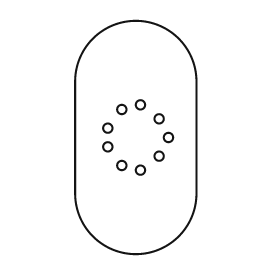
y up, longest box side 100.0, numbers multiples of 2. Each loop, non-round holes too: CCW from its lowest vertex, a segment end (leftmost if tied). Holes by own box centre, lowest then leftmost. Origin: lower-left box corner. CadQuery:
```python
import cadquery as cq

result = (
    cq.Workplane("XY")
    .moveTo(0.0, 26.0)
    .threePointArc((26.0, 0.0), (52.0, 26.0))
    .lineTo(52.0, 74.0)
    .threePointArc((26.0, 100.0), (0.0, 74.0))
    .close()
    .moveTo(28.0, 36.0)
    .circle(2.0)
    .moveTo(20.0, 38.0)
    .circle(2.0)
    .moveTo(36.0, 42.0)
    .circle(2.0)
    .moveTo(14.0, 46.0)
    .circle(2.0)
    .moveTo(40.0, 50.0)
    .circle(2.0)
    .moveTo(14.0, 54.0)
    .circle(2.0)
    .moveTo(36.0, 58.0)
    .circle(2.0)
    .moveTo(20.0, 62.0)
    .circle(2.0)
    .moveTo(28.0, 64.0)
    .circle(2.0)
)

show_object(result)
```